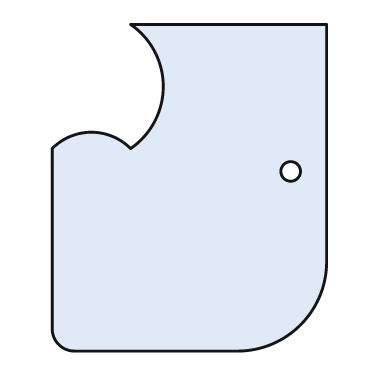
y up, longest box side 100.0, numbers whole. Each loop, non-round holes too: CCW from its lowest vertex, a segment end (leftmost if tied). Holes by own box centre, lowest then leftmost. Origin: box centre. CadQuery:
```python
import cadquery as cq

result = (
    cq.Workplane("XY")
    .moveTo(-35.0, -50.0)
    .lineTo(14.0, -50.0)
    .threePointArc((34.0, -42.0), (42.0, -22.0))
    .lineTo(42.0, 50.0)
    .lineTo(-18.0, 50.0)
    .threePointArc((-8.0, 31.0), (-18.0, 12.0))
    .threePointArc((-30.0, 17.0), (-42.0, 12.0))
    .lineTo(-42.0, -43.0)
    .threePointArc((-40.0, -48.0), (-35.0, -50.0))
    .close()
    .moveTo(31.0, 5.0)
    .circle(3.0)
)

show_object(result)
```